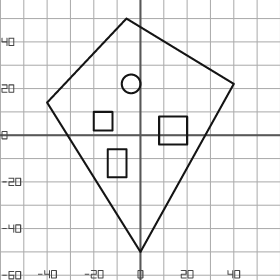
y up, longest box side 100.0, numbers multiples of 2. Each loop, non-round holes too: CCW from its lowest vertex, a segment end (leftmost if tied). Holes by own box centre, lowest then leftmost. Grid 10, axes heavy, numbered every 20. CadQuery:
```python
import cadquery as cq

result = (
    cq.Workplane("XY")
    .moveTo(0.0, -50.0)
    .lineTo(40.0, 22.0)
    .lineTo(-6.0, 50.0)
    .lineTo(-40.0, 14.0)
    .close()
    .moveTo(-14.0, -18.0)
    .lineTo(-6.0, -18.0)
    .lineTo(-6.0, -6.0)
    .lineTo(-14.0, -6.0)
    .close()
    .moveTo(8.0, -4.0)
    .lineTo(20.0, -4.0)
    .lineTo(20.0, 8.0)
    .lineTo(8.0, 8.0)
    .close()
    .moveTo(-20.0, 2.0)
    .lineTo(-12.0, 2.0)
    .lineTo(-12.0, 10.0)
    .lineTo(-20.0, 10.0)
    .close()
    .moveTo(-4.0, 22.0)
    .circle(4.0)
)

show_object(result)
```